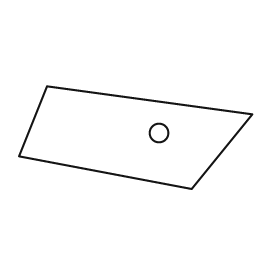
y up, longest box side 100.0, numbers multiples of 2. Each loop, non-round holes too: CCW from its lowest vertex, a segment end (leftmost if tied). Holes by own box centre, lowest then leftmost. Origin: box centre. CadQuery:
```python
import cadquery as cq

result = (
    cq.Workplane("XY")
    .moveTo(24.0, -22.0)
    .lineTo(50.0, 10.0)
    .lineTo(-38.0, 22.0)
    .lineTo(-50.0, -8.0)
    .close()
    .moveTo(10.0, 2.0)
    .circle(4.0)
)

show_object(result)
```